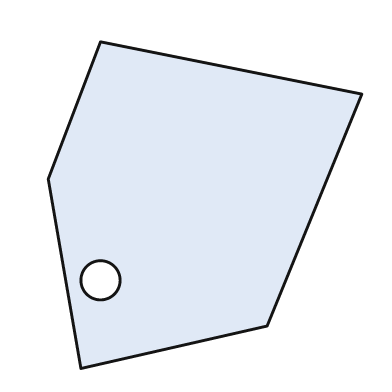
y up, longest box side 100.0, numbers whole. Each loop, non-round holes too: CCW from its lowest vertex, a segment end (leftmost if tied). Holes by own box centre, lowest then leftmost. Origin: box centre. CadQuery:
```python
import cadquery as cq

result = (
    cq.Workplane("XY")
    .moveTo(-38.0, -50.0)
    .lineTo(19.0, -37.0)
    .lineTo(48.0, 34.0)
    .lineTo(-32.0, 50.0)
    .lineTo(-48.0, 8.0)
    .close()
    .moveTo(-32.0, -23.0)
    .circle(6.0)
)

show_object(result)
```